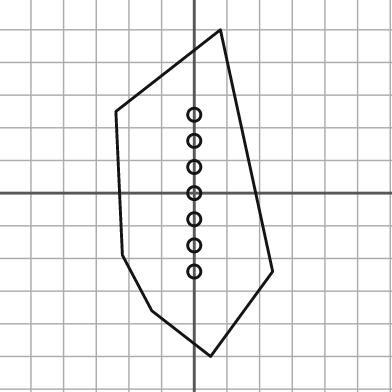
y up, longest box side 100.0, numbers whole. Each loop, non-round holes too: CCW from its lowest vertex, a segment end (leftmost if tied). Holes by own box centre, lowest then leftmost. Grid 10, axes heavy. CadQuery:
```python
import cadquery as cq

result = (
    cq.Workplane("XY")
    .moveTo(5.0, -50.0)
    .lineTo(24.0, -24.0)
    .lineTo(8.0, 50.0)
    .lineTo(-24.0, 25.0)
    .lineTo(-22.0, -19.0)
    .lineTo(-13.0, -36.0)
    .close()
    .moveTo(0.0, -24.0)
    .circle(2.0)
    .moveTo(0.0, -16.0)
    .circle(2.0)
    .moveTo(0.0, -8.0)
    .circle(2.0)
    .moveTo(0.0, 0.0)
    .circle(2.0)
    .moveTo(0.0, 8.0)
    .circle(2.0)
    .moveTo(0.0, 16.0)
    .circle(2.0)
    .moveTo(0.0, 24.0)
    .circle(2.0)
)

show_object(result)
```